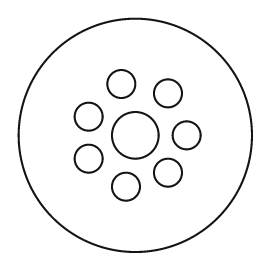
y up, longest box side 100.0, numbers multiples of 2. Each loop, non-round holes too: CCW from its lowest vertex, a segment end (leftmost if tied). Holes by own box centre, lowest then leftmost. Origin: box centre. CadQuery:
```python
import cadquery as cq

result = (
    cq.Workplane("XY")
    .moveTo(0.0, 0.0)
    .circle(50.0)
    .moveTo(-4.0, -22.0)
    .circle(6.0)
    .moveTo(14.0, -16.0)
    .circle(6.0)
    .moveTo(-20.0, -10.0)
    .circle(6.0)
    .moveTo(0.0, 0.0)
    .circle(10.0)
    .moveTo(22.0, 0.0)
    .circle(6.0)
    .moveTo(-20.0, 8.0)
    .circle(6.0)
    .moveTo(14.0, 18.0)
    .circle(6.0)
    .moveTo(-6.0, 22.0)
    .circle(6.0)
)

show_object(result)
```